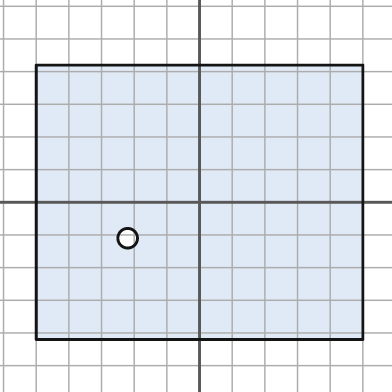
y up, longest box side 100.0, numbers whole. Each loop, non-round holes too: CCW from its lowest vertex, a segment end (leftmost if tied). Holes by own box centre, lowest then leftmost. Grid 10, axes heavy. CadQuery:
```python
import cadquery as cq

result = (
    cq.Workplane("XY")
    .moveTo(-50.0, -42.0)
    .lineTo(50.0, -42.0)
    .lineTo(50.0, 42.0)
    .lineTo(-50.0, 42.0)
    .close()
    .moveTo(-22.0, -11.0)
    .circle(3.0)
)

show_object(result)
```